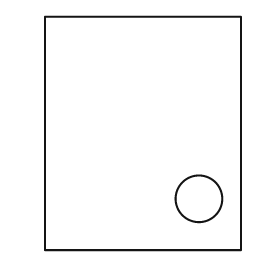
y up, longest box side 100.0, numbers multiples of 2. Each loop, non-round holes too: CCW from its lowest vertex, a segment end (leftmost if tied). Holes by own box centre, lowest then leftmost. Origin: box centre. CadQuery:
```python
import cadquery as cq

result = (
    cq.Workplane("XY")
    .moveTo(-42.0, -50.0)
    .lineTo(42.0, -50.0)
    .lineTo(42.0, 50.0)
    .lineTo(-42.0, 50.0)
    .close()
    .moveTo(24.0, -28.0)
    .circle(10.0)
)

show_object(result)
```